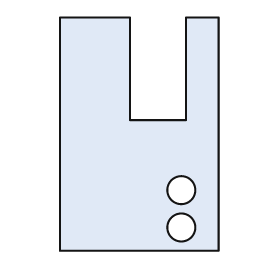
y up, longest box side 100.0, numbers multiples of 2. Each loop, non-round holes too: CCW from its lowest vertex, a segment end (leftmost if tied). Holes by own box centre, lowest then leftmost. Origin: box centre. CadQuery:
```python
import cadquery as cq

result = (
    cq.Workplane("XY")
    .moveTo(-34.0, -50.0)
    .lineTo(34.0, -50.0)
    .lineTo(34.0, 50.0)
    .lineTo(20.0, 50.0)
    .lineTo(20.0, 6.0)
    .lineTo(-4.0, 6.0)
    .lineTo(-4.0, 50.0)
    .lineTo(-34.0, 50.0)
    .close()
    .moveTo(18.0, -40.0)
    .circle(6.0)
    .moveTo(18.0, -24.0)
    .circle(6.0)
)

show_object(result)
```